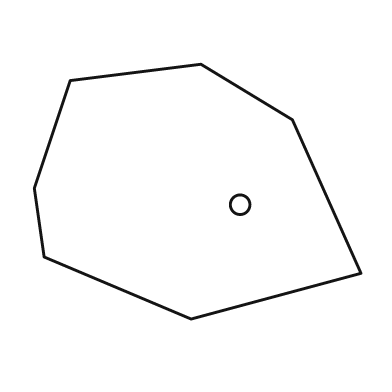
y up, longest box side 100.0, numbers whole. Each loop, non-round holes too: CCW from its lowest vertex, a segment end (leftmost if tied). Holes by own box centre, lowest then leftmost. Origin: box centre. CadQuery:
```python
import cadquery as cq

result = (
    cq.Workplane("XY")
    .moveTo(-2.0, -39.0)
    .lineTo(50.0, -25.0)
    .lineTo(29.0, 22.0)
    .lineTo(1.0, 39.0)
    .lineTo(-39.0, 34.0)
    .lineTo(-50.0, 1.0)
    .lineTo(-47.0, -20.0)
    .close()
    .moveTo(13.0, -4.0)
    .circle(3.0)
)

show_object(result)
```